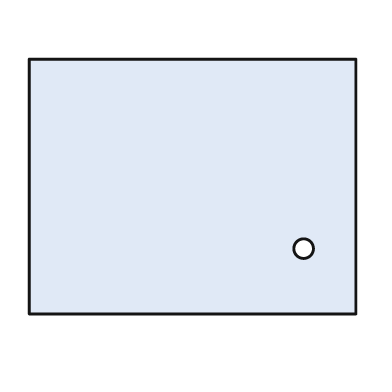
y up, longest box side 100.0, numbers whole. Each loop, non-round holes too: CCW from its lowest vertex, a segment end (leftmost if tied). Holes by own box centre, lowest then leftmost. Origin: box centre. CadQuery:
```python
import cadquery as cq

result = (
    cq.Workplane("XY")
    .moveTo(-50.0, -39.0)
    .lineTo(50.0, -39.0)
    .lineTo(50.0, 39.0)
    .lineTo(-50.0, 39.0)
    .close()
    .moveTo(34.0, -19.0)
    .circle(3.0)
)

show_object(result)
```